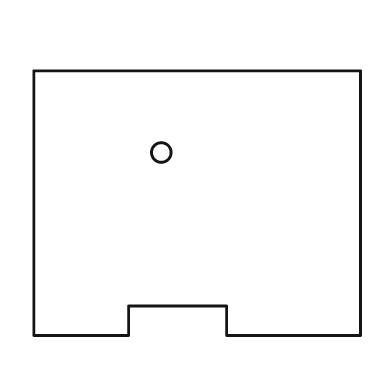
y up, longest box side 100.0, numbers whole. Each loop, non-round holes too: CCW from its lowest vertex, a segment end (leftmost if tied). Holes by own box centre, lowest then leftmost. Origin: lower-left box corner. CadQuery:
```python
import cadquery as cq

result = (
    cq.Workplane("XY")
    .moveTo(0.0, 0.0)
    .lineTo(29.0, 0.0)
    .lineTo(29.0, 9.0)
    .lineTo(59.0, 9.0)
    .lineTo(59.0, 0.0)
    .lineTo(100.0, 0.0)
    .lineTo(100.0, 81.0)
    .lineTo(0.0, 81.0)
    .close()
    .moveTo(39.0, 56.0)
    .circle(3.0)
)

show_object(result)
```